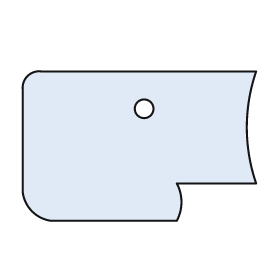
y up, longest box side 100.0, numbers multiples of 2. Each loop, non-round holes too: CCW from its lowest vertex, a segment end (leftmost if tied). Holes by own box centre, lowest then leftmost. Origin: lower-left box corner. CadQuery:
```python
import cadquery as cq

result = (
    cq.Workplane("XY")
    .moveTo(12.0, 0.0)
    .lineTo(66.0, 0.0)
    .threePointArc((68.0, 8.0), (66.0, 16.0))
    .lineTo(100.0, 16.0)
    .threePointArc((96.0, 40.0), (100.0, 64.0))
    .lineTo(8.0, 64.0)
    .threePointArc((2.0, 62.0), (0.0, 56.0))
    .lineTo(0.0, 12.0)
    .threePointArc((4.0, 4.0), (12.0, 0.0))
    .close()
    .moveTo(52.0, 48.0)
    .circle(4.0)
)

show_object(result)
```